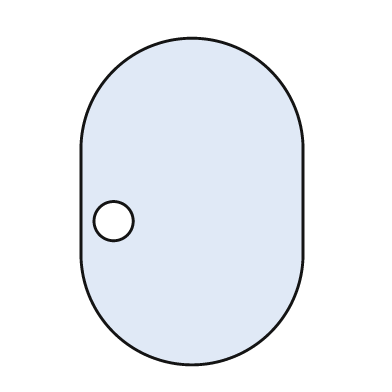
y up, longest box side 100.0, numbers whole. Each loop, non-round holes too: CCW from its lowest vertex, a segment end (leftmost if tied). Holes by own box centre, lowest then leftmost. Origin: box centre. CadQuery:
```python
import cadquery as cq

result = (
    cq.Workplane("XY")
    .moveTo(-34.0, -16.0)
    .threePointArc((0.0, -50.0), (34.0, -16.0))
    .lineTo(34.0, 16.0)
    .threePointArc((0.0, 50.0), (-34.0, 16.0))
    .close()
    .moveTo(-24.0, -6.0)
    .circle(6.0)
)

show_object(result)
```